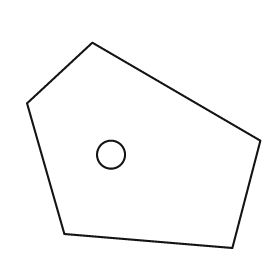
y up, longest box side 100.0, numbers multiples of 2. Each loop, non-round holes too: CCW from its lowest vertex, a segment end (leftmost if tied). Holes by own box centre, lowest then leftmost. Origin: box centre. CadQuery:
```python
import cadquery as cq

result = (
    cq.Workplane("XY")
    .moveTo(38.0, -44.0)
    .lineTo(50.0, 2.0)
    .lineTo(-22.0, 44.0)
    .lineTo(-50.0, 18.0)
    .lineTo(-34.0, -38.0)
    .close()
    .moveTo(-14.0, -4.0)
    .circle(6.0)
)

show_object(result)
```